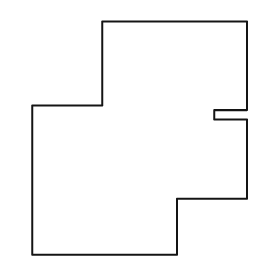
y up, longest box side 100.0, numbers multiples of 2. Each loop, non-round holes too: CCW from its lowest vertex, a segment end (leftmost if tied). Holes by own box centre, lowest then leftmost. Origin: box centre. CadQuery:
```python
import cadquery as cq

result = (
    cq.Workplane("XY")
    .moveTo(-46.0, -50.0)
    .lineTo(16.0, -50.0)
    .lineTo(16.0, -26.0)
    .lineTo(46.0, -26.0)
    .lineTo(46.0, 8.0)
    .lineTo(32.0, 8.0)
    .lineTo(32.0, 12.0)
    .lineTo(46.0, 12.0)
    .lineTo(46.0, 50.0)
    .lineTo(-16.0, 50.0)
    .lineTo(-16.0, 14.0)
    .lineTo(-46.0, 14.0)
    .close()
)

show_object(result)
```